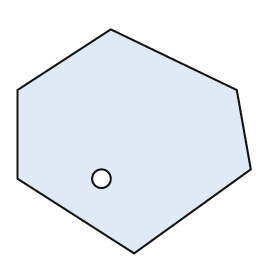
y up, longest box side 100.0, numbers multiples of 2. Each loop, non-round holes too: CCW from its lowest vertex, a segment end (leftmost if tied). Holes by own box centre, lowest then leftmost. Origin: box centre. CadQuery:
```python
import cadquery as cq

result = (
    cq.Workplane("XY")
    .moveTo(0.0, -48.0)
    .lineTo(50.0, -12.0)
    .lineTo(44.0, 22.0)
    .lineTo(-10.0, 48.0)
    .lineTo(-50.0, 22.0)
    .lineTo(-50.0, -16.0)
    .close()
    .moveTo(-14.0, -16.0)
    .circle(4.0)
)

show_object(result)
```